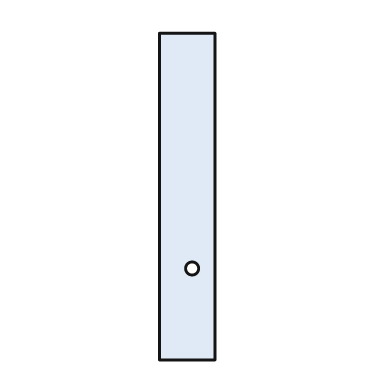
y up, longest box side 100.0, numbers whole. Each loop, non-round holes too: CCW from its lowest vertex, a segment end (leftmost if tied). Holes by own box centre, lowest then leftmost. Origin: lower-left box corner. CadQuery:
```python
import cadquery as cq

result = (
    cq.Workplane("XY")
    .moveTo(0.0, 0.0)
    .lineTo(17.0, 0.0)
    .lineTo(17.0, 100.0)
    .lineTo(0.0, 100.0)
    .close()
    .moveTo(10.0, 28.0)
    .circle(2.0)
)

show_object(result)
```